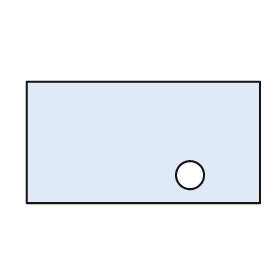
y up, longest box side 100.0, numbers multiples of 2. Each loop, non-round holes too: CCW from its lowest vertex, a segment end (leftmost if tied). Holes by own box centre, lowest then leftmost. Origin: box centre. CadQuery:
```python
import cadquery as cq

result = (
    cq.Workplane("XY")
    .moveTo(-50.0, -26.0)
    .lineTo(50.0, -26.0)
    .lineTo(50.0, 26.0)
    .lineTo(-50.0, 26.0)
    .close()
    .moveTo(20.0, -14.0)
    .circle(6.0)
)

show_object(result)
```